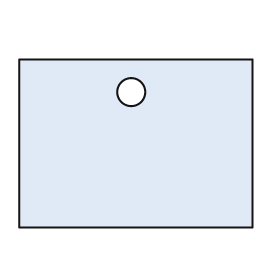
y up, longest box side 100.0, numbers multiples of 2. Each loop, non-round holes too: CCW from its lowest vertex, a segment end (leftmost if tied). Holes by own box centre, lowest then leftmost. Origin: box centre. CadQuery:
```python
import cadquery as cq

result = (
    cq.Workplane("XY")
    .moveTo(-50.0, -36.0)
    .lineTo(50.0, -36.0)
    .lineTo(50.0, 36.0)
    .lineTo(-50.0, 36.0)
    .close()
    .moveTo(-2.0, 22.0)
    .circle(6.0)
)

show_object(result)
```